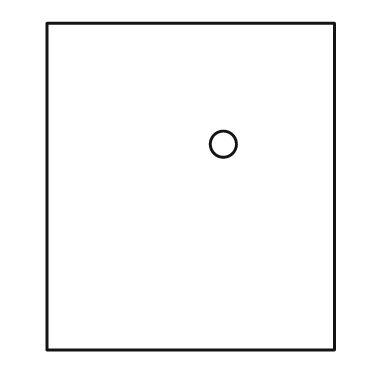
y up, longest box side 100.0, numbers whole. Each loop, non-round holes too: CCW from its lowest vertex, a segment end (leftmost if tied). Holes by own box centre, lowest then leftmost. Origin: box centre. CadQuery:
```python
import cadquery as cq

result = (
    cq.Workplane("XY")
    .moveTo(-44.0, -50.0)
    .lineTo(44.0, -50.0)
    .lineTo(44.0, 50.0)
    .lineTo(-44.0, 50.0)
    .close()
    .moveTo(10.0, 13.0)
    .circle(4.0)
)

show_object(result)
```